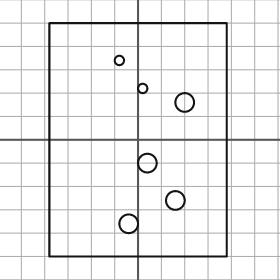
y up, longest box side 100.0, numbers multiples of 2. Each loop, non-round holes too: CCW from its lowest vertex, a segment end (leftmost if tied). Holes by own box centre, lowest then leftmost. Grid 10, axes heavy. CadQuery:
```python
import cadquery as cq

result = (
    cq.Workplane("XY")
    .moveTo(-38.0, -50.0)
    .lineTo(38.0, -50.0)
    .lineTo(38.0, 50.0)
    .lineTo(-38.0, 50.0)
    .close()
    .moveTo(-4.0, -36.0)
    .circle(4.0)
    .moveTo(16.0, -26.0)
    .circle(4.0)
    .moveTo(4.0, -10.0)
    .circle(4.0)
    .moveTo(20.0, 16.0)
    .circle(4.0)
    .moveTo(2.0, 22.0)
    .circle(2.0)
    .moveTo(-8.0, 34.0)
    .circle(2.0)
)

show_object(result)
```